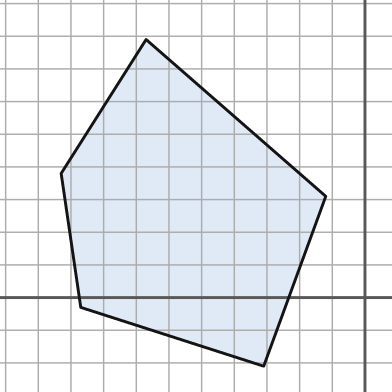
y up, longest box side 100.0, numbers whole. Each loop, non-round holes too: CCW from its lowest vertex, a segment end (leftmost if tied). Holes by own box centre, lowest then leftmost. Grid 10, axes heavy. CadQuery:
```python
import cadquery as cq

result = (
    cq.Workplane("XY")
    .moveTo(-31.0, -21.0)
    .lineTo(-12.0, 31.0)
    .lineTo(-67.0, 79.0)
    .lineTo(-93.0, 38.0)
    .lineTo(-87.0, -3.0)
    .close()
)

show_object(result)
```